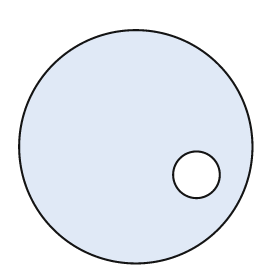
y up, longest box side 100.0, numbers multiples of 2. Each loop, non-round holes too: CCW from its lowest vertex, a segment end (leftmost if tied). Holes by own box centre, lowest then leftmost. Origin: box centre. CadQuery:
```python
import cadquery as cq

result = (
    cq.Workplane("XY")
    .moveTo(0.0, 0.0)
    .circle(50.0)
    .moveTo(26.0, -12.0)
    .circle(10.0)
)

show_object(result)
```